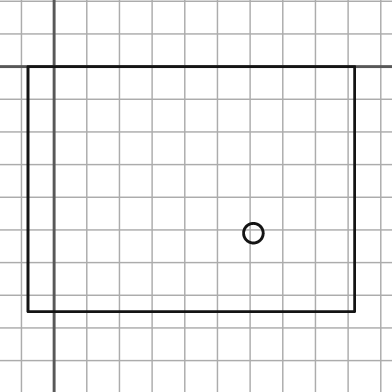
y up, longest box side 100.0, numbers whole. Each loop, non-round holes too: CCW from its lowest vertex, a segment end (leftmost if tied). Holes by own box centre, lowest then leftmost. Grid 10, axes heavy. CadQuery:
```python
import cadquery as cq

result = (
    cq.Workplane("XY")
    .moveTo(-8.0, -75.0)
    .lineTo(92.0, -75.0)
    .lineTo(92.0, 0.0)
    .lineTo(-8.0, 0.0)
    .close()
    .moveTo(61.0, -51.0)
    .circle(3.0)
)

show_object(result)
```